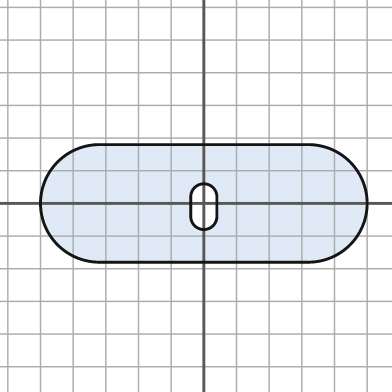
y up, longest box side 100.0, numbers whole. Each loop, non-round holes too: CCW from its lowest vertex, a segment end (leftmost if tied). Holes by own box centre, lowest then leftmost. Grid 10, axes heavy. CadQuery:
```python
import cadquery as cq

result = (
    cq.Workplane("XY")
    .moveTo(-32.0, -18.0)
    .lineTo(32.0, -18.0)
    .threePointArc((50.0, 0.0), (32.0, 18.0))
    .lineTo(-32.0, 18.0)
    .threePointArc((-50.0, 0.0), (-32.0, -18.0))
    .close()
    .moveTo(-4.0, -4.0)
    .threePointArc((0.0, -8.0), (4.0, -4.0))
    .lineTo(4.0, 2.0)
    .threePointArc((0.0, 6.0), (-4.0, 2.0))
    .close()
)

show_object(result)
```